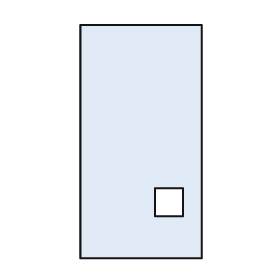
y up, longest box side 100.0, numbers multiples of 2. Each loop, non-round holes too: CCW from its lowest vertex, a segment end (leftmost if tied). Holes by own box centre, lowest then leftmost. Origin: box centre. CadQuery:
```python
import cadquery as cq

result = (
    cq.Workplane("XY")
    .moveTo(-26.0, -50.0)
    .lineTo(26.0, -50.0)
    .lineTo(26.0, 50.0)
    .lineTo(-26.0, 50.0)
    .close()
    .moveTo(6.0, -32.0)
    .lineTo(18.0, -32.0)
    .lineTo(18.0, -20.0)
    .lineTo(6.0, -20.0)
    .close()
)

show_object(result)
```